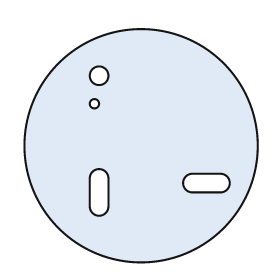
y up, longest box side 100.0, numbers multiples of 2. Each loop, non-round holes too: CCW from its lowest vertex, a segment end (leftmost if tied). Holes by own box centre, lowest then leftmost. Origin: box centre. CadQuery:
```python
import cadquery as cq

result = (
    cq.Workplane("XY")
    .moveTo(0.0, 0.0)
    .circle(50.0)
    .moveTo(-22.0, -26.0)
    .threePointArc((-18.0, -30.0), (-14.0, -26.0))
    .lineTo(-14.0, -14.0)
    .threePointArc((-18.0, -10.0), (-22.0, -14.0))
    .close()
    .moveTo(22.0, -20.0)
    .lineTo(34.0, -20.0)
    .threePointArc((38.0, -16.0), (34.0, -12.0))
    .lineTo(22.0, -12.0)
    .threePointArc((18.0, -16.0), (22.0, -20.0))
    .close()
    .moveTo(-20.0, 18.0)
    .circle(2.0)
    .moveTo(-18.0, 30.0)
    .circle(4.0)
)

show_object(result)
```